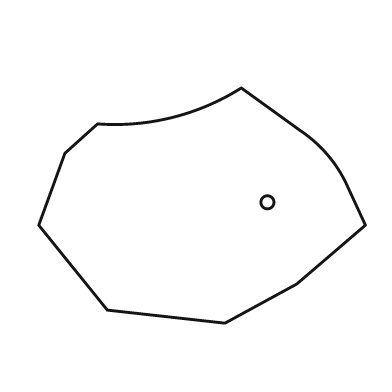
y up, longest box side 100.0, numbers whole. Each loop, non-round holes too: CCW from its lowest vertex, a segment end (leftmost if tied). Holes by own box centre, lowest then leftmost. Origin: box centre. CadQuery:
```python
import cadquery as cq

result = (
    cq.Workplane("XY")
    .moveTo(7.0, -36.0)
    .lineTo(29.0, -24.0)
    .lineTo(50.0, -6.0)
    .lineTo(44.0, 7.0)
    .threePointArc((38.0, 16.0), (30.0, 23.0))
    .lineTo(12.0, 36.0)
    .threePointArc((-9.0, 27.0), (-32.0, 25.0))
    .lineTo(-42.0, 16.0)
    .lineTo(-50.0, -6.0)
    .lineTo(-29.0, -32.0)
    .close()
    .moveTo(20.0, 1.0)
    .circle(2.0)
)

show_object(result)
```